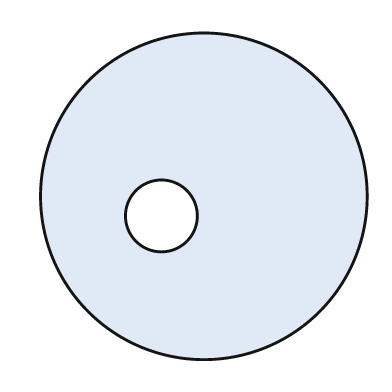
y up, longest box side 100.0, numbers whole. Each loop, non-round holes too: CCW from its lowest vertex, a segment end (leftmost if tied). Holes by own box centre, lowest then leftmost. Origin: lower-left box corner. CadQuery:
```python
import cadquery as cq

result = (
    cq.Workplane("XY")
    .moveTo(50.0, 50.0)
    .circle(50.0)
    .moveTo(37.0, 44.0)
    .circle(11.0)
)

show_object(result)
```